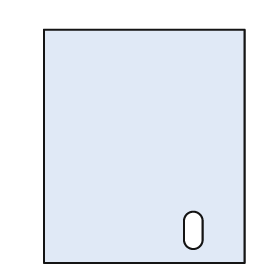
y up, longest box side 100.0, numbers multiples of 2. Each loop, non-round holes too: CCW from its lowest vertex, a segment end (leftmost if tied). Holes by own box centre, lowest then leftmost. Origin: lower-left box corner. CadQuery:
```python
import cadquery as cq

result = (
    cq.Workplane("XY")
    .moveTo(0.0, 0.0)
    .lineTo(86.0, 0.0)
    .lineTo(86.0, 100.0)
    .lineTo(0.0, 100.0)
    .close()
    .moveTo(60.0, 10.0)
    .threePointArc((64.0, 6.0), (68.0, 10.0))
    .lineTo(68.0, 18.0)
    .threePointArc((64.0, 22.0), (60.0, 18.0))
    .close()
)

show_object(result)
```